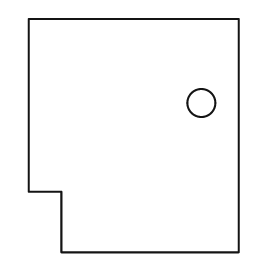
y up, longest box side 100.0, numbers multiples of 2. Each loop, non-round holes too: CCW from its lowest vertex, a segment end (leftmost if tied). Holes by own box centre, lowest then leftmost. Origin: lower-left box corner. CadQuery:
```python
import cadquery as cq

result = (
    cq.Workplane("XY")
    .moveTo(14.0, 0.0)
    .lineTo(90.0, 0.0)
    .lineTo(90.0, 100.0)
    .lineTo(0.0, 100.0)
    .lineTo(0.0, 26.0)
    .lineTo(14.0, 26.0)
    .close()
    .moveTo(74.0, 64.0)
    .circle(6.0)
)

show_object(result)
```